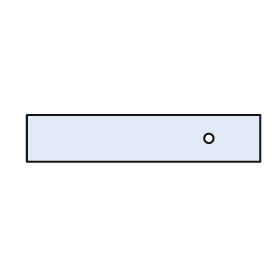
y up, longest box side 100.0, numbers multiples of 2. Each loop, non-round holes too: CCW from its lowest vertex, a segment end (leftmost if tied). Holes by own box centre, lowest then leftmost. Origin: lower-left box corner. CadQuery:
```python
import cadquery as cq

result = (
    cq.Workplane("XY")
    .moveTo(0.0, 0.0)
    .lineTo(100.0, 0.0)
    .lineTo(100.0, 20.0)
    .lineTo(0.0, 20.0)
    .close()
    .moveTo(78.0, 10.0)
    .circle(2.0)
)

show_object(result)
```